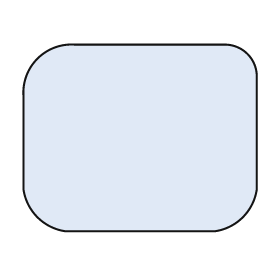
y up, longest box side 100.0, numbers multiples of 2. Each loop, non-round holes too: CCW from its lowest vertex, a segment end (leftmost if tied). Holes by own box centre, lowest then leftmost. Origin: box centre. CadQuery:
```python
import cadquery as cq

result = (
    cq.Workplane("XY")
    .moveTo(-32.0, -40.0)
    .lineTo(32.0, -40.0)
    .threePointArc((44.0, -34.0), (50.0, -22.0))
    .lineTo(50.0, 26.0)
    .threePointArc((46.0, 36.0), (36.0, 40.0))
    .lineTo(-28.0, 40.0)
    .threePointArc((-44.0, 34.0), (-50.0, 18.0))
    .lineTo(-50.0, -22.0)
    .threePointArc((-44.0, -34.0), (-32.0, -40.0))
    .close()
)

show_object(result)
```